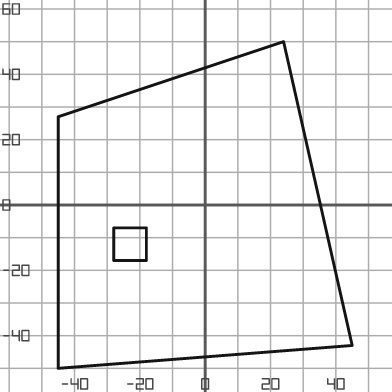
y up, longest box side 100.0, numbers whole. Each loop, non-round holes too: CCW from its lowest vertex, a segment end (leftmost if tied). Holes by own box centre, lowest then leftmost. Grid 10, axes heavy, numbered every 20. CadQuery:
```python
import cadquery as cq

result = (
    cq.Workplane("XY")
    .moveTo(-45.0, -50.0)
    .lineTo(45.0, -43.0)
    .lineTo(24.0, 50.0)
    .lineTo(-45.0, 27.0)
    .close()
    .moveTo(-28.0, -17.0)
    .lineTo(-18.0, -17.0)
    .lineTo(-18.0, -7.0)
    .lineTo(-28.0, -7.0)
    .close()
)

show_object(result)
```